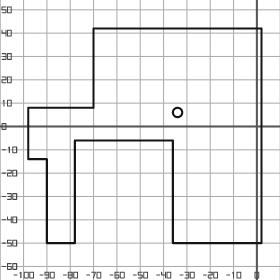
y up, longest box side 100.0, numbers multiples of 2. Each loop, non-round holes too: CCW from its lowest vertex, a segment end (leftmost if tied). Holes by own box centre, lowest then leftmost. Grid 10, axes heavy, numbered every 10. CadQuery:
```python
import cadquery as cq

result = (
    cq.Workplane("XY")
    .moveTo(-90.0, -50.0)
    .lineTo(-78.0, -50.0)
    .lineTo(-78.0, -6.0)
    .lineTo(-36.0, -6.0)
    .lineTo(-36.0, -50.0)
    .lineTo(2.0, -50.0)
    .lineTo(2.0, 42.0)
    .lineTo(-70.0, 42.0)
    .lineTo(-70.0, 8.0)
    .lineTo(-98.0, 8.0)
    .lineTo(-98.0, -14.0)
    .lineTo(-90.0, -14.0)
    .close()
    .moveTo(-34.0, 6.0)
    .circle(2.0)
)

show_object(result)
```